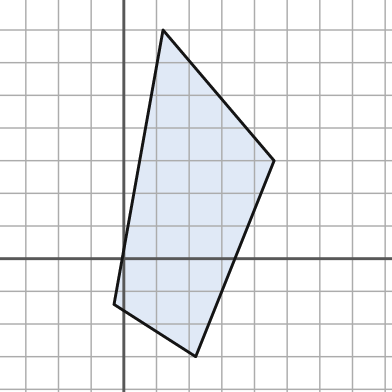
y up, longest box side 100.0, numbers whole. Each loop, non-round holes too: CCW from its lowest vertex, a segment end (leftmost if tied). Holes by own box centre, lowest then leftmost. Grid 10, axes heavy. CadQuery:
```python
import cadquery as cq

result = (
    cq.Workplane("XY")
    .moveTo(22.0, -30.0)
    .lineTo(46.0, 30.0)
    .lineTo(12.0, 70.0)
    .lineTo(-3.0, -14.0)
    .close()
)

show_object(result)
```